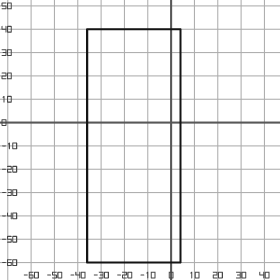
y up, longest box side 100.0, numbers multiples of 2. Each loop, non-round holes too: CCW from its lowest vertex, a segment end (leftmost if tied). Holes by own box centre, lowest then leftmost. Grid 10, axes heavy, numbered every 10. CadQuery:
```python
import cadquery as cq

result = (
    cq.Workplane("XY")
    .moveTo(-36.0, -60.0)
    .lineTo(4.0, -60.0)
    .lineTo(4.0, 40.0)
    .lineTo(-36.0, 40.0)
    .close()
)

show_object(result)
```